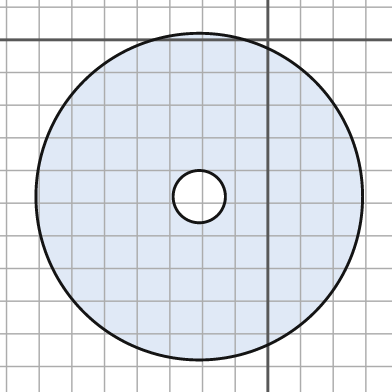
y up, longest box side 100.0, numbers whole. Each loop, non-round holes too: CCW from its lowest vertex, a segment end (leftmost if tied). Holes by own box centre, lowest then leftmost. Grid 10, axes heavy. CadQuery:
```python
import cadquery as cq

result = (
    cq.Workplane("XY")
    .moveTo(-21.0, -48.0)
    .circle(50.0)
    .moveTo(-21.0, -48.0)
    .circle(8.0)
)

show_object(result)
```